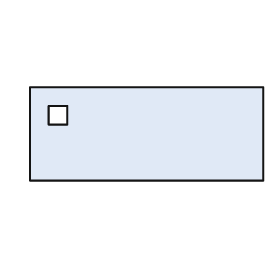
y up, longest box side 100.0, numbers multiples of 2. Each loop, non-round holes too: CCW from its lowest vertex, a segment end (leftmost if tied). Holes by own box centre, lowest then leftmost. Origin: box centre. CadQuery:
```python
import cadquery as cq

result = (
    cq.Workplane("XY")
    .moveTo(-50.0, -20.0)
    .lineTo(50.0, -20.0)
    .lineTo(50.0, 20.0)
    .lineTo(-50.0, 20.0)
    .close()
    .moveTo(-42.0, 4.0)
    .lineTo(-34.0, 4.0)
    .lineTo(-34.0, 12.0)
    .lineTo(-42.0, 12.0)
    .close()
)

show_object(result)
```